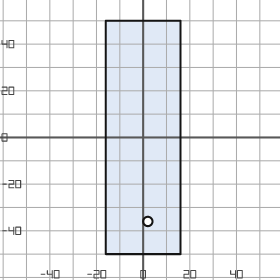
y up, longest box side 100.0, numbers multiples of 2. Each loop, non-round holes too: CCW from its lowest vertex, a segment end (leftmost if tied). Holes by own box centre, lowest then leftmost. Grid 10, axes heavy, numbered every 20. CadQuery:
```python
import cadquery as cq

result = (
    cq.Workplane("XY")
    .moveTo(-16.0, -50.0)
    .lineTo(16.0, -50.0)
    .lineTo(16.0, 50.0)
    .lineTo(-16.0, 50.0)
    .close()
    .moveTo(2.0, -36.0)
    .circle(2.0)
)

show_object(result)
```